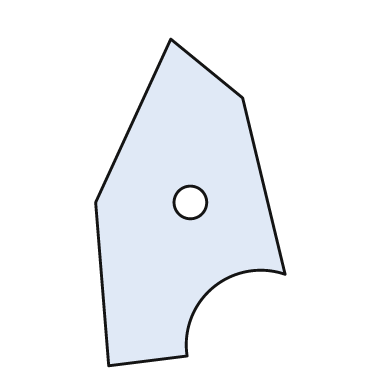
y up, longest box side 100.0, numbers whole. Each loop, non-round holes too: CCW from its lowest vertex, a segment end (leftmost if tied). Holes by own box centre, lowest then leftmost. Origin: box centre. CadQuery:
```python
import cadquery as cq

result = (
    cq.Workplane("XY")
    .moveTo(-25.0, -50.0)
    .lineTo(-1.0, -47.0)
    .threePointArc((7.0, -26.0), (29.0, -22.0))
    .lineTo(16.0, 32.0)
    .lineTo(-6.0, 50.0)
    .lineTo(-29.0, 0.0)
    .close()
    .moveTo(0.0, 0.0)
    .circle(5.0)
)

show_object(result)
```